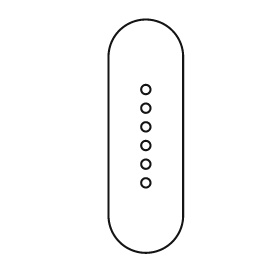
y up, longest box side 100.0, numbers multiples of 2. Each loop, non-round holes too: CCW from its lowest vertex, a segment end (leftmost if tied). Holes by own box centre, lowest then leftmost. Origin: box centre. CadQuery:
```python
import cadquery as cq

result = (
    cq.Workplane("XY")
    .moveTo(-16.0, -34.0)
    .threePointArc((0.0, -50.0), (16.0, -34.0))
    .lineTo(16.0, 34.0)
    .threePointArc((0.0, 50.0), (-16.0, 34.0))
    .close()
    .moveTo(0.0, -20.0)
    .circle(2.0)
    .moveTo(0.0, -12.0)
    .circle(2.0)
    .moveTo(0.0, -4.0)
    .circle(2.0)
    .moveTo(0.0, 4.0)
    .circle(2.0)
    .moveTo(0.0, 12.0)
    .circle(2.0)
    .moveTo(0.0, 20.0)
    .circle(2.0)
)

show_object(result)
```